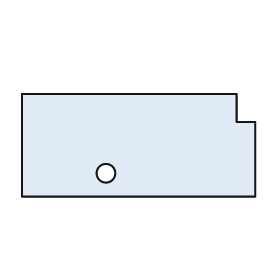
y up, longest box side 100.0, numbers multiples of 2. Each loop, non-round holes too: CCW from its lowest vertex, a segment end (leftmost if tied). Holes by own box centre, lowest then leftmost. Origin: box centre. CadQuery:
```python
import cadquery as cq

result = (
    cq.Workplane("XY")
    .moveTo(-50.0, -22.0)
    .lineTo(50.0, -22.0)
    .lineTo(50.0, 10.0)
    .lineTo(42.0, 10.0)
    .lineTo(42.0, 22.0)
    .lineTo(-50.0, 22.0)
    .close()
    .moveTo(-14.0, -12.0)
    .circle(4.0)
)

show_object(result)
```